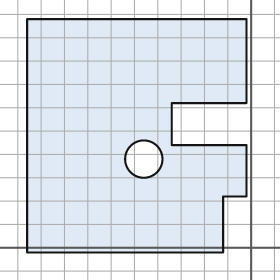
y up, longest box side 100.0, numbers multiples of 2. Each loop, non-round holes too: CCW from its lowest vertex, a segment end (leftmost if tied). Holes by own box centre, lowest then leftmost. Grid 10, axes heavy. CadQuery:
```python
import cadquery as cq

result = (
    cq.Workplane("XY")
    .moveTo(-96.0, -2.0)
    .lineTo(-12.0, -2.0)
    .lineTo(-12.0, 22.0)
    .lineTo(-2.0, 22.0)
    .lineTo(-2.0, 44.0)
    .lineTo(-34.0, 44.0)
    .lineTo(-34.0, 62.0)
    .lineTo(-2.0, 62.0)
    .lineTo(-2.0, 98.0)
    .lineTo(-96.0, 98.0)
    .close()
    .moveTo(-46.0, 38.0)
    .circle(8.0)
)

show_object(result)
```